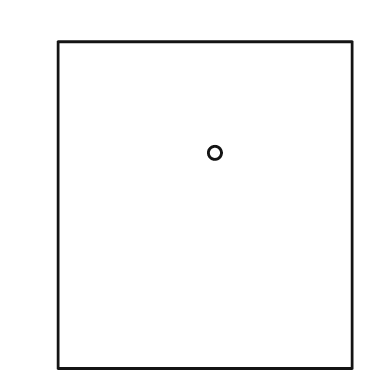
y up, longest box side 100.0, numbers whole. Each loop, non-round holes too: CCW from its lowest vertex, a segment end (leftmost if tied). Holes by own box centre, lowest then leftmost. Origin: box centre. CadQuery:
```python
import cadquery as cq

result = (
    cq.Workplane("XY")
    .moveTo(-45.0, -50.0)
    .lineTo(45.0, -50.0)
    .lineTo(45.0, 50.0)
    .lineTo(-45.0, 50.0)
    .close()
    .moveTo(3.0, 16.0)
    .circle(2.0)
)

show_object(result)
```